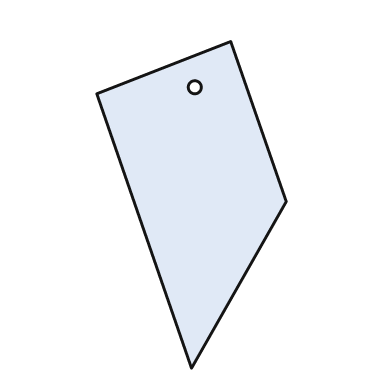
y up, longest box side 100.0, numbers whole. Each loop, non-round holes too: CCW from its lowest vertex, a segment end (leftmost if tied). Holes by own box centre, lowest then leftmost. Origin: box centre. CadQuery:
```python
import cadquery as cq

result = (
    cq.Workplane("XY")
    .moveTo(0.0, -50.0)
    .lineTo(29.0, 1.0)
    .lineTo(12.0, 50.0)
    .lineTo(-29.0, 34.0)
    .close()
    .moveTo(1.0, 36.0)
    .circle(2.0)
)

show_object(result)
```